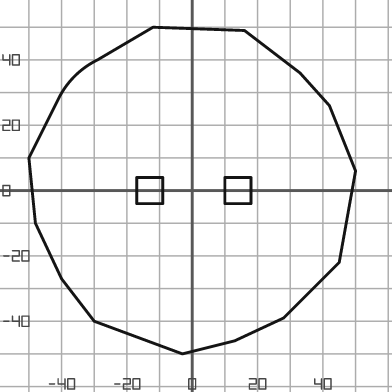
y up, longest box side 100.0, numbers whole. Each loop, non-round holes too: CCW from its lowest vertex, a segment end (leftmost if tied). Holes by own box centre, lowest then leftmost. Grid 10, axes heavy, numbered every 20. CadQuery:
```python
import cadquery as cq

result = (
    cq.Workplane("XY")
    .moveTo(-3.0, -50.0)
    .lineTo(13.0, -46.0)
    .lineTo(28.0, -39.0)
    .lineTo(45.0, -22.0)
    .lineTo(50.0, 6.0)
    .lineTo(42.0, 26.0)
    .lineTo(33.0, 36.0)
    .lineTo(16.0, 49.0)
    .lineTo(-12.0, 50.0)
    .lineTo(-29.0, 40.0)
    .threePointArc((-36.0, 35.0), (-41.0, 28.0))
    .lineTo(-50.0, 10.0)
    .lineTo(-48.0, -10.0)
    .lineTo(-40.0, -27.0)
    .lineTo(-30.0, -40.0)
    .close()
    .moveTo(-17.0, -4.0)
    .lineTo(-9.0, -4.0)
    .lineTo(-9.0, 4.0)
    .lineTo(-17.0, 4.0)
    .close()
    .moveTo(10.0, -4.0)
    .lineTo(18.0, -4.0)
    .lineTo(18.0, 4.0)
    .lineTo(10.0, 4.0)
    .close()
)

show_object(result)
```